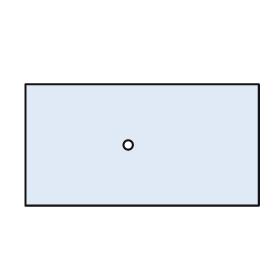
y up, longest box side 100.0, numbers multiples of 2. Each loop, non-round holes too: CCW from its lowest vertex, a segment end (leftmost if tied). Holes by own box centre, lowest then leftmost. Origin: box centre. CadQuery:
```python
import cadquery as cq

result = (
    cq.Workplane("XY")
    .moveTo(-50.0, -26.0)
    .lineTo(50.0, -26.0)
    .lineTo(50.0, 26.0)
    .lineTo(-50.0, 26.0)
    .close()
    .moveTo(-6.0, 0.0)
    .circle(2.0)
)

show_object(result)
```